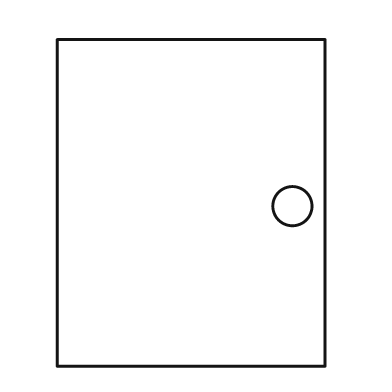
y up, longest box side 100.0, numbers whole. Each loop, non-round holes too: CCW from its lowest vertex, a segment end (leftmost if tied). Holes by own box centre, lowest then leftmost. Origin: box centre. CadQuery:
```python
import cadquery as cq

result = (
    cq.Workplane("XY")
    .moveTo(-41.0, -50.0)
    .lineTo(41.0, -50.0)
    .lineTo(41.0, 50.0)
    .lineTo(-41.0, 50.0)
    .close()
    .moveTo(31.0, -1.0)
    .circle(6.0)
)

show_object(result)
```